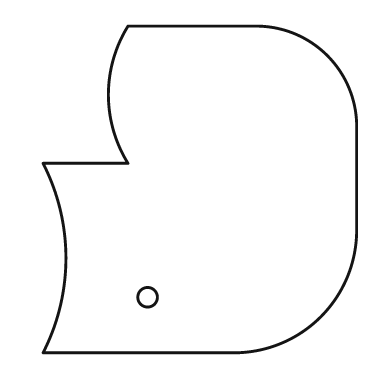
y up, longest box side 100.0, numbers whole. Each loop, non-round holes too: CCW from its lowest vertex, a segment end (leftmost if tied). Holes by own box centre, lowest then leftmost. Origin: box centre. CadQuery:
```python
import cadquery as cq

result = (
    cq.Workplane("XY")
    .moveTo(-48.0, -50.0)
    .lineTo(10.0, -50.0)
    .threePointArc((37.0, -39.0), (48.0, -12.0))
    .lineTo(48.0, 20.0)
    .threePointArc((39.0, 41.0), (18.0, 50.0))
    .lineTo(-22.0, 50.0)
    .threePointArc((-28.0, 29.0), (-22.0, 8.0))
    .lineTo(-48.0, 8.0)
    .threePointArc((-41.0, -21.0), (-48.0, -50.0))
    .close()
    .moveTo(-16.0, -33.0)
    .circle(3.0)
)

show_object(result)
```